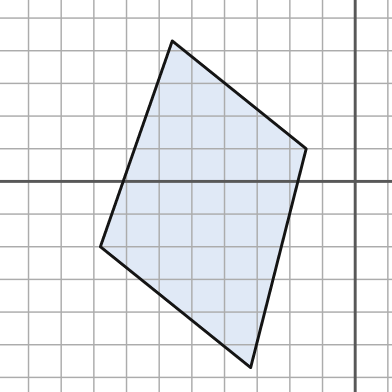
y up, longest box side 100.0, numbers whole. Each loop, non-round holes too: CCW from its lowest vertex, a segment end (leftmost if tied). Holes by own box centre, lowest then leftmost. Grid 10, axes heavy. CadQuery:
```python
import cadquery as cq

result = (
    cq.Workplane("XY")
    .moveTo(-32.0, -57.0)
    .lineTo(-15.0, 10.0)
    .lineTo(-56.0, 43.0)
    .lineTo(-78.0, -20.0)
    .close()
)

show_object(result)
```